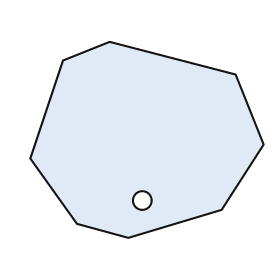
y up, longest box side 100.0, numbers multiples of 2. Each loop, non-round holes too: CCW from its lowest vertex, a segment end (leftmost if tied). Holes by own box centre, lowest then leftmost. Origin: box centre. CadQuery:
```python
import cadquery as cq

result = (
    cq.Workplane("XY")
    .moveTo(-8.0, -42.0)
    .lineTo(32.0, -30.0)
    .lineTo(50.0, -2.0)
    .lineTo(38.0, 28.0)
    .lineTo(-16.0, 42.0)
    .lineTo(-36.0, 34.0)
    .lineTo(-50.0, -8.0)
    .lineTo(-30.0, -36.0)
    .close()
    .moveTo(-2.0, -26.0)
    .circle(4.0)
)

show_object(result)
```